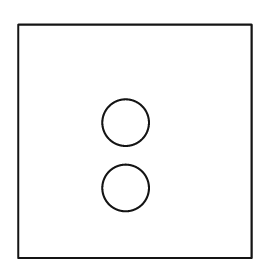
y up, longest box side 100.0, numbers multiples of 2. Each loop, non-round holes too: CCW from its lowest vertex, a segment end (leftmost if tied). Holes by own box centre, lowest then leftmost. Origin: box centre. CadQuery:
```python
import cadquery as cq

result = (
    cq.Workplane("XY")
    .moveTo(-50.0, -50.0)
    .lineTo(50.0, -50.0)
    .lineTo(50.0, 50.0)
    .lineTo(-50.0, 50.0)
    .close()
    .moveTo(-4.0, -20.0)
    .circle(10.0)
    .moveTo(-4.0, 8.0)
    .circle(10.0)
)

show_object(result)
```